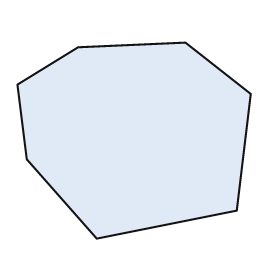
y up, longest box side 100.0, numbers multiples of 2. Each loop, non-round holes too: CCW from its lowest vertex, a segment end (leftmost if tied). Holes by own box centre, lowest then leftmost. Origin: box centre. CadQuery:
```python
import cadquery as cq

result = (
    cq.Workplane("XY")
    .moveTo(-16.0, -42.0)
    .lineTo(44.0, -30.0)
    .lineTo(50.0, 20.0)
    .lineTo(22.0, 42.0)
    .lineTo(-24.0, 40.0)
    .lineTo(-50.0, 24.0)
    .lineTo(-46.0, -8.0)
    .close()
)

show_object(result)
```